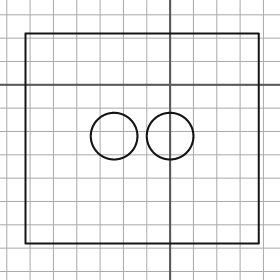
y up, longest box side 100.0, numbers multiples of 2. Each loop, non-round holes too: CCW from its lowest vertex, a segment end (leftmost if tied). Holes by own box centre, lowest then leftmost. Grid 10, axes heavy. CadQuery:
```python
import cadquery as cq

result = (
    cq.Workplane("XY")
    .moveTo(-62.0, -68.0)
    .lineTo(38.0, -68.0)
    .lineTo(38.0, 22.0)
    .lineTo(-62.0, 22.0)
    .close()
    .moveTo(-24.0, -22.0)
    .circle(10.0)
    .moveTo(0.0, -22.0)
    .circle(10.0)
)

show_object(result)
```